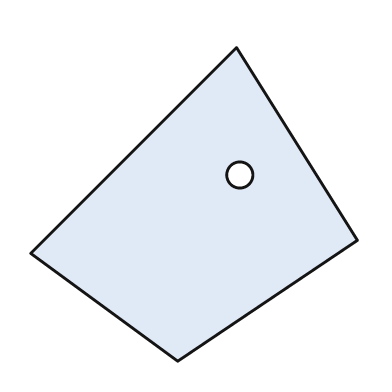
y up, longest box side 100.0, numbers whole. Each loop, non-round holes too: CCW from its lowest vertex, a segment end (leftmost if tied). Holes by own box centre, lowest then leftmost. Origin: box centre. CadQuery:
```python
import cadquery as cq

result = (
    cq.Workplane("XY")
    .moveTo(-5.0, -48.0)
    .lineTo(50.0, -11.0)
    .lineTo(13.0, 48.0)
    .lineTo(-50.0, -15.0)
    .close()
    .moveTo(14.0, 9.0)
    .circle(4.0)
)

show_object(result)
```